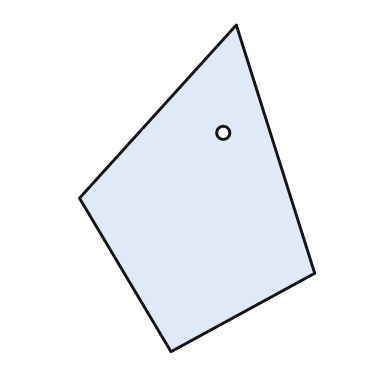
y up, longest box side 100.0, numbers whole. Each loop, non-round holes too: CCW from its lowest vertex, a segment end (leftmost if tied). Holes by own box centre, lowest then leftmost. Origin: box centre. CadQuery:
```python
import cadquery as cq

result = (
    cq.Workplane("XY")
    .moveTo(-8.0, -50.0)
    .lineTo(36.0, -26.0)
    .lineTo(12.0, 50.0)
    .lineTo(-36.0, -3.0)
    .close()
    .moveTo(8.0, 17.0)
    .circle(2.0)
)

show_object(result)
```